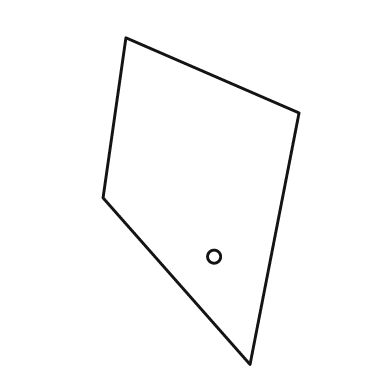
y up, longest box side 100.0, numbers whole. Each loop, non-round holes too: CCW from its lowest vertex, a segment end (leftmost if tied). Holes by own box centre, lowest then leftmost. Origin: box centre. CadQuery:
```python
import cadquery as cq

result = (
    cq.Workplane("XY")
    .moveTo(15.0, -50.0)
    .lineTo(30.0, 27.0)
    .lineTo(-23.0, 50.0)
    .lineTo(-30.0, 1.0)
    .close()
    .moveTo(4.0, -17.0)
    .circle(2.0)
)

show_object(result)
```